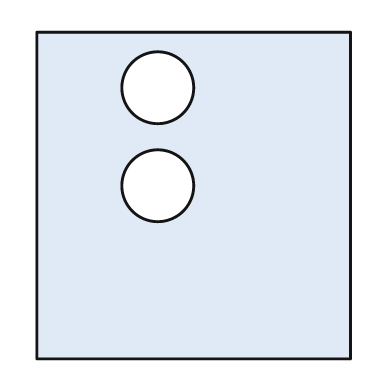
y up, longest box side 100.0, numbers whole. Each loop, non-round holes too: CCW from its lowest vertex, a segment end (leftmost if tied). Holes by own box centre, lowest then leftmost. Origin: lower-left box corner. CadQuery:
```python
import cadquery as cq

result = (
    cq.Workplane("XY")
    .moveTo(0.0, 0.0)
    .lineTo(96.0, 0.0)
    .lineTo(96.0, 100.0)
    .lineTo(0.0, 100.0)
    .close()
    .moveTo(37.0, 53.0)
    .circle(11.0)
    .moveTo(37.0, 83.0)
    .circle(11.0)
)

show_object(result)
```